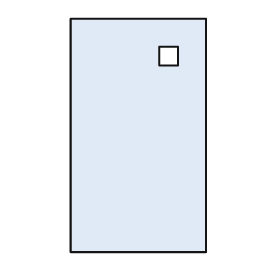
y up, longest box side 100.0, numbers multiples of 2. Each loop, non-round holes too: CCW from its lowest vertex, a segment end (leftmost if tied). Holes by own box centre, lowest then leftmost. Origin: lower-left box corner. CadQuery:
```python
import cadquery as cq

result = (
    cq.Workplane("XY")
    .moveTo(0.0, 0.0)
    .lineTo(58.0, 0.0)
    .lineTo(58.0, 100.0)
    .lineTo(0.0, 100.0)
    .close()
    .moveTo(38.0, 80.0)
    .lineTo(46.0, 80.0)
    .lineTo(46.0, 88.0)
    .lineTo(38.0, 88.0)
    .close()
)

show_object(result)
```